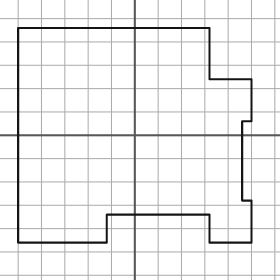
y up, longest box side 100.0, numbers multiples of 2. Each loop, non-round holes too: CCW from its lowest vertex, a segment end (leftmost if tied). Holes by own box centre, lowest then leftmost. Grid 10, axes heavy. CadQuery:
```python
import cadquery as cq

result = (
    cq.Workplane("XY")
    .moveTo(-50.0, -46.0)
    .lineTo(-12.0, -46.0)
    .lineTo(-12.0, -34.0)
    .lineTo(32.0, -34.0)
    .lineTo(32.0, -46.0)
    .lineTo(50.0, -46.0)
    .lineTo(50.0, -28.0)
    .lineTo(46.0, -28.0)
    .lineTo(46.0, 6.0)
    .lineTo(50.0, 6.0)
    .lineTo(50.0, 24.0)
    .lineTo(32.0, 24.0)
    .lineTo(32.0, 46.0)
    .lineTo(-50.0, 46.0)
    .close()
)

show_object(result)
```